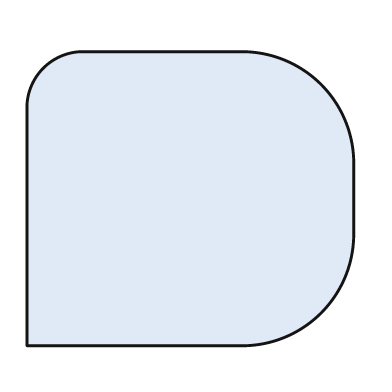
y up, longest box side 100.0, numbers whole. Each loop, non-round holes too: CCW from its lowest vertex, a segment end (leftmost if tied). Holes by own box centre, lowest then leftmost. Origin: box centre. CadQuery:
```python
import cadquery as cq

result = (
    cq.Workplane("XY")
    .moveTo(-50.0, -45.0)
    .lineTo(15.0, -45.0)
    .threePointArc((40.0, -35.0), (50.0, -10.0))
    .lineTo(50.0, 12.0)
    .threePointArc((40.0, 35.0), (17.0, 45.0))
    .lineTo(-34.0, 45.0)
    .threePointArc((-45.0, 40.0), (-50.0, 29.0))
    .close()
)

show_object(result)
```